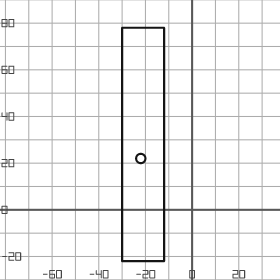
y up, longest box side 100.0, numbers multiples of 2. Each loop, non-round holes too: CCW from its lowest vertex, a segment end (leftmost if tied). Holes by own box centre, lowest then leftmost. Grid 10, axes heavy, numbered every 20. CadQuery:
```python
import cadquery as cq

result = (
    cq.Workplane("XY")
    .moveTo(-30.0, -22.0)
    .lineTo(-12.0, -22.0)
    .lineTo(-12.0, 78.0)
    .lineTo(-30.0, 78.0)
    .close()
    .moveTo(-22.0, 22.0)
    .circle(2.0)
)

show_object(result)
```